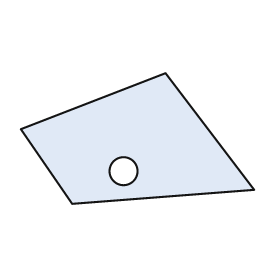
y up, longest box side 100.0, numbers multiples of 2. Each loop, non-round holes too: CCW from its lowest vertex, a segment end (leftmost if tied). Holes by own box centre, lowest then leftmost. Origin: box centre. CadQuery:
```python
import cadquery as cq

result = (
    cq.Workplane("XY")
    .moveTo(-28.0, -28.0)
    .lineTo(50.0, -22.0)
    .lineTo(12.0, 28.0)
    .lineTo(-50.0, 4.0)
    .close()
    .moveTo(-6.0, -14.0)
    .circle(6.0)
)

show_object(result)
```